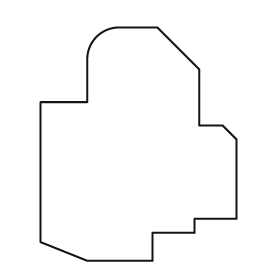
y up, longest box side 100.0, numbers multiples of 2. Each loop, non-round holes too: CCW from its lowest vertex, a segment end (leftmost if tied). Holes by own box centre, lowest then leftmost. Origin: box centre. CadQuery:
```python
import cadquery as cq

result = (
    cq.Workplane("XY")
    .moveTo(-22.0, -50.0)
    .lineTo(6.0, -50.0)
    .lineTo(6.0, -38.0)
    .lineTo(24.0, -38.0)
    .lineTo(24.0, -32.0)
    .lineTo(42.0, -32.0)
    .lineTo(42.0, 2.0)
    .lineTo(36.0, 8.0)
    .lineTo(26.0, 8.0)
    .lineTo(26.0, 32.0)
    .lineTo(8.0, 50.0)
    .lineTo(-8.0, 50.0)
    .threePointArc((-18.0, 46.0), (-22.0, 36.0))
    .lineTo(-22.0, 18.0)
    .lineTo(-42.0, 18.0)
    .lineTo(-42.0, -42.0)
    .close()
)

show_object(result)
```